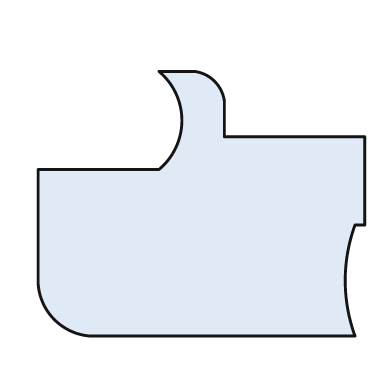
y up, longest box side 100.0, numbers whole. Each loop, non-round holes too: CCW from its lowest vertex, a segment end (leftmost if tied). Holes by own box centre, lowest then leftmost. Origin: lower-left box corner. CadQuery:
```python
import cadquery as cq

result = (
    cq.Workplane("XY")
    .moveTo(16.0, 0.0)
    .lineTo(97.0, 0.0)
    .threePointArc((94.0, 17.0), (97.0, 34.0))
    .lineTo(100.0, 34.0)
    .lineTo(100.0, 61.0)
    .lineTo(57.0, 61.0)
    .lineTo(57.0, 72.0)
    .threePointArc((54.0, 78.0), (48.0, 81.0))
    .lineTo(37.0, 81.0)
    .threePointArc((44.0, 66.0), (37.0, 51.0))
    .lineTo(0.0, 51.0)
    .lineTo(0.0, 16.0)
    .threePointArc((5.0, 5.0), (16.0, 0.0))
    .close()
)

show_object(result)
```